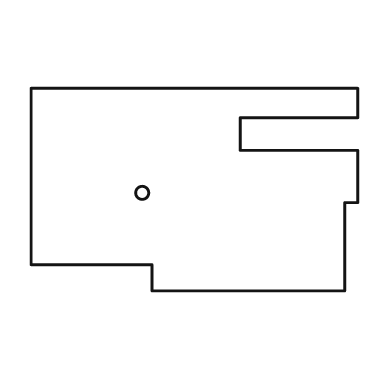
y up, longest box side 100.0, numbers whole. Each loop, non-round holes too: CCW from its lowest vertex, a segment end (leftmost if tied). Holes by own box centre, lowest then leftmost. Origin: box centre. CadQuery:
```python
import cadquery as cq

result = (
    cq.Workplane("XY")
    .moveTo(-13.0, -31.0)
    .lineTo(46.0, -31.0)
    .lineTo(46.0, -4.0)
    .lineTo(50.0, -4.0)
    .lineTo(50.0, 12.0)
    .lineTo(14.0, 12.0)
    .lineTo(14.0, 22.0)
    .lineTo(50.0, 22.0)
    .lineTo(50.0, 31.0)
    .lineTo(-50.0, 31.0)
    .lineTo(-50.0, -23.0)
    .lineTo(-13.0, -23.0)
    .close()
    .moveTo(-16.0, -1.0)
    .circle(2.0)
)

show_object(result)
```